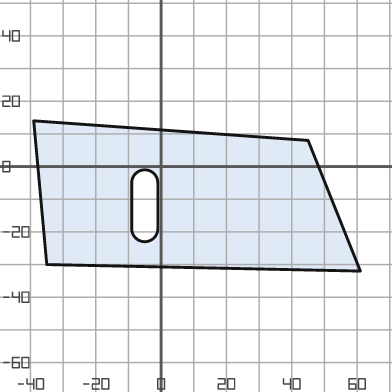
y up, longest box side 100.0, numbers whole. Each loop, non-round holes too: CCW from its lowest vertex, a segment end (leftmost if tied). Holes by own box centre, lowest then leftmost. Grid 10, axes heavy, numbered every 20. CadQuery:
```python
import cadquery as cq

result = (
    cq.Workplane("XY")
    .moveTo(61.0, -32.0)
    .lineTo(45.0, 8.0)
    .lineTo(-39.0, 14.0)
    .lineTo(-35.0, -30.0)
    .close()
    .moveTo(-9.0, -19.0)
    .threePointArc((-5.0, -23.0), (-1.0, -19.0))
    .lineTo(-1.0, -5.0)
    .threePointArc((-5.0, -1.0), (-9.0, -5.0))
    .close()
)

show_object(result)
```